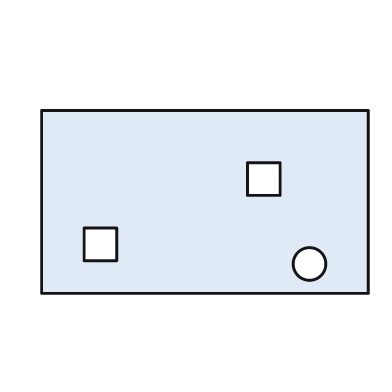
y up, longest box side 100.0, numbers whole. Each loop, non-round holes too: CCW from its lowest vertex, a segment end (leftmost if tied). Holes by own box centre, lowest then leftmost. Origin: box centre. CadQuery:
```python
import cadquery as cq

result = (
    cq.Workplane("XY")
    .moveTo(-50.0, -28.0)
    .lineTo(50.0, -28.0)
    .lineTo(50.0, 28.0)
    .lineTo(-50.0, 28.0)
    .close()
    .moveTo(32.0, -19.0)
    .circle(5.0)
    .moveTo(-37.0, -18.0)
    .lineTo(-27.0, -18.0)
    .lineTo(-27.0, -8.0)
    .lineTo(-37.0, -8.0)
    .close()
    .moveTo(13.0, 2.0)
    .lineTo(23.0, 2.0)
    .lineTo(23.0, 12.0)
    .lineTo(13.0, 12.0)
    .close()
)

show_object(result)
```